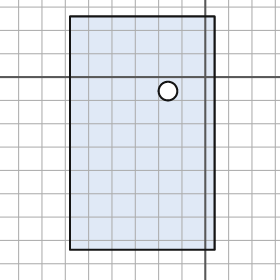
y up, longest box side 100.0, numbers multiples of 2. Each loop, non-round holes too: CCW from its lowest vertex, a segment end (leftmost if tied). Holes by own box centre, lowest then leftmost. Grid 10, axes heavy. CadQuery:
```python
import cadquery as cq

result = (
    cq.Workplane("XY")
    .moveTo(-58.0, -74.0)
    .lineTo(4.0, -74.0)
    .lineTo(4.0, 26.0)
    .lineTo(-58.0, 26.0)
    .close()
    .moveTo(-16.0, -6.0)
    .circle(4.0)
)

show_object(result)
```